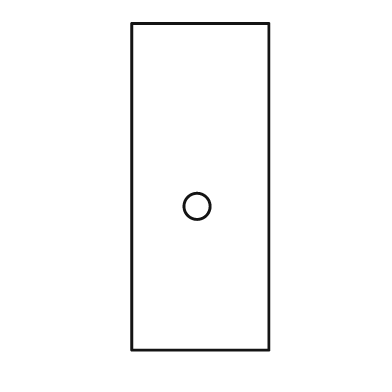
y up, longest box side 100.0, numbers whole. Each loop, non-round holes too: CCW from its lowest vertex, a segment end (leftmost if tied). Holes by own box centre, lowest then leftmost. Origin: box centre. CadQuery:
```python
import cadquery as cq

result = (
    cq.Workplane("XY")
    .moveTo(-21.0, -50.0)
    .lineTo(21.0, -50.0)
    .lineTo(21.0, 50.0)
    .lineTo(-21.0, 50.0)
    .close()
    .moveTo(-1.0, -6.0)
    .circle(4.0)
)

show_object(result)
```